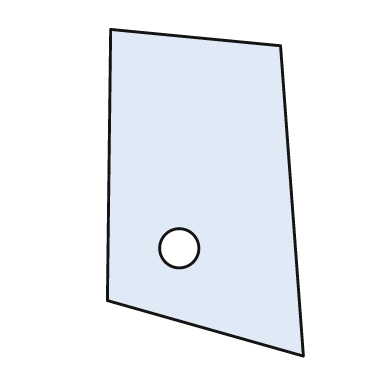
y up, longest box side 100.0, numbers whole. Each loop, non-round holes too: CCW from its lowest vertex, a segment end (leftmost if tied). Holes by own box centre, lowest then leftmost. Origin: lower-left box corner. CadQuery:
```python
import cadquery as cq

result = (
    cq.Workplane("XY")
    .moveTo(60.0, 0.0)
    .lineTo(53.0, 95.0)
    .lineTo(1.0, 100.0)
    .lineTo(0.0, 17.0)
    .close()
    .moveTo(22.0, 33.0)
    .circle(6.0)
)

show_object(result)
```